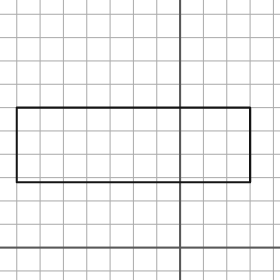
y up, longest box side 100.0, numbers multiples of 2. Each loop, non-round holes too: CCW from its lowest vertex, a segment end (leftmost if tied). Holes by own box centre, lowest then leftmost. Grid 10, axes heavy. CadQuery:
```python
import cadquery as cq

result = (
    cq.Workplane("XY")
    .moveTo(-70.0, 28.0)
    .lineTo(30.0, 28.0)
    .lineTo(30.0, 60.0)
    .lineTo(-70.0, 60.0)
    .close()
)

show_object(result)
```